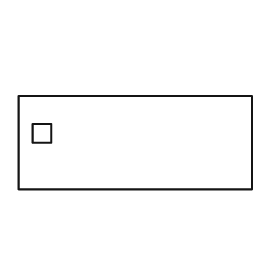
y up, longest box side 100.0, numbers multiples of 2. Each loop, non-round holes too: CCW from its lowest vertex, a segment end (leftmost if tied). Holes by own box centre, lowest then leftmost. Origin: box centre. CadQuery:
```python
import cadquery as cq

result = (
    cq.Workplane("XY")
    .moveTo(-50.0, -20.0)
    .lineTo(50.0, -20.0)
    .lineTo(50.0, 20.0)
    .lineTo(-50.0, 20.0)
    .close()
    .moveTo(-44.0, 0.0)
    .lineTo(-36.0, 0.0)
    .lineTo(-36.0, 8.0)
    .lineTo(-44.0, 8.0)
    .close()
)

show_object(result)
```